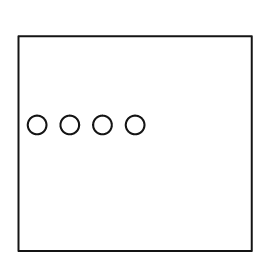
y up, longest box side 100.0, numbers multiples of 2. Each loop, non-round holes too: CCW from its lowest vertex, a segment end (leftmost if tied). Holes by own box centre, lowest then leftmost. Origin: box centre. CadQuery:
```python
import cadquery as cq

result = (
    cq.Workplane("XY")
    .moveTo(-50.0, -46.0)
    .lineTo(50.0, -46.0)
    .lineTo(50.0, 46.0)
    .lineTo(-50.0, 46.0)
    .close()
    .moveTo(-42.0, 8.0)
    .circle(4.0)
    .moveTo(-28.0, 8.0)
    .circle(4.0)
    .moveTo(-14.0, 8.0)
    .circle(4.0)
    .moveTo(0.0, 8.0)
    .circle(4.0)
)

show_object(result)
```